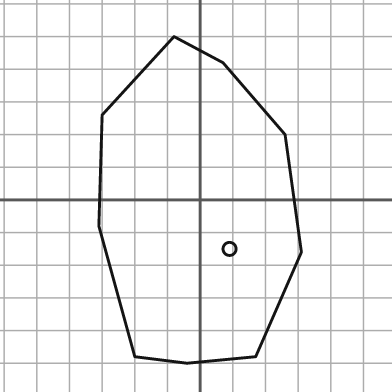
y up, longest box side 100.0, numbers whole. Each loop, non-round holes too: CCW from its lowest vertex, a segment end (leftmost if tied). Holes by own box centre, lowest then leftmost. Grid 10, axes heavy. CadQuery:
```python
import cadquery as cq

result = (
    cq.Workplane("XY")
    .moveTo(-4.0, -50.0)
    .lineTo(17.0, -48.0)
    .lineTo(31.0, -16.0)
    .lineTo(26.0, 20.0)
    .lineTo(7.0, 42.0)
    .lineTo(-8.0, 50.0)
    .lineTo(-30.0, 26.0)
    .lineTo(-31.0, -8.0)
    .lineTo(-20.0, -48.0)
    .close()
    .moveTo(9.0, -15.0)
    .circle(2.0)
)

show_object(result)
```